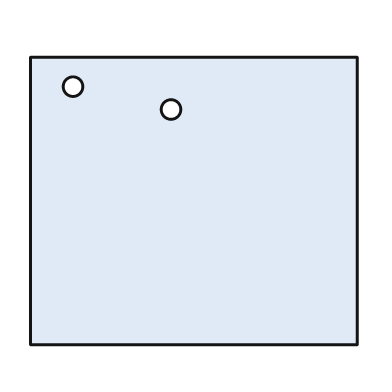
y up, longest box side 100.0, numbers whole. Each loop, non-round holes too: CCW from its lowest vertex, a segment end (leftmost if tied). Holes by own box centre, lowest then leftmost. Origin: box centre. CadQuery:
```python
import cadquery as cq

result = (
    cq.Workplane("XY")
    .moveTo(-50.0, -44.0)
    .lineTo(50.0, -44.0)
    .lineTo(50.0, 44.0)
    .lineTo(-50.0, 44.0)
    .close()
    .moveTo(-7.0, 28.0)
    .circle(3.0)
    .moveTo(-37.0, 35.0)
    .circle(3.0)
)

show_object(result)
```